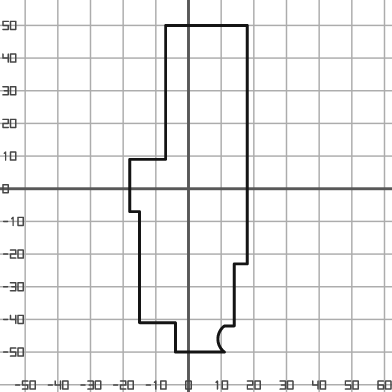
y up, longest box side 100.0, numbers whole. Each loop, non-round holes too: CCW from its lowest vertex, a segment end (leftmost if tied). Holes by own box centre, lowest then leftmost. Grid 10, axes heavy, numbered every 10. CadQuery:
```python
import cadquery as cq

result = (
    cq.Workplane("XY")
    .moveTo(-4.0, -50.0)
    .lineTo(11.0, -50.0)
    .threePointArc((9.0, -46.0), (11.0, -42.0))
    .lineTo(14.0, -42.0)
    .lineTo(14.0, -23.0)
    .lineTo(18.0, -23.0)
    .lineTo(18.0, 50.0)
    .lineTo(-7.0, 50.0)
    .lineTo(-7.0, 9.0)
    .lineTo(-18.0, 9.0)
    .lineTo(-18.0, -7.0)
    .lineTo(-15.0, -7.0)
    .lineTo(-15.0, -41.0)
    .lineTo(-4.0, -41.0)
    .close()
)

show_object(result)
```